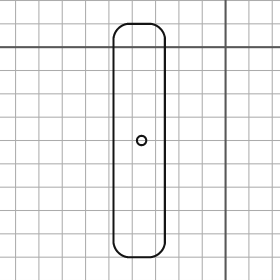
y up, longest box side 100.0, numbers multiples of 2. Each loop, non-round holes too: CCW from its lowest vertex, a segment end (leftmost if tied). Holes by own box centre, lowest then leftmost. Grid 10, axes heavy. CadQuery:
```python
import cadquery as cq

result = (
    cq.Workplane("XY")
    .moveTo(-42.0, -90.0)
    .lineTo(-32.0, -90.0)
    .threePointArc((-28.0, -88.0), (-26.0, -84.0))
    .lineTo(-26.0, 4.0)
    .threePointArc((-28.0, 8.0), (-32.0, 10.0))
    .lineTo(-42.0, 10.0)
    .threePointArc((-46.0, 8.0), (-48.0, 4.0))
    .lineTo(-48.0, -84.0)
    .threePointArc((-46.0, -88.0), (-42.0, -90.0))
    .close()
    .moveTo(-36.0, -40.0)
    .circle(2.0)
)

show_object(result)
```